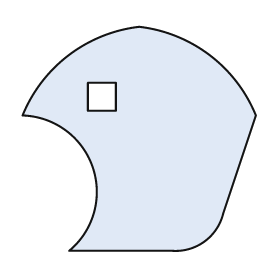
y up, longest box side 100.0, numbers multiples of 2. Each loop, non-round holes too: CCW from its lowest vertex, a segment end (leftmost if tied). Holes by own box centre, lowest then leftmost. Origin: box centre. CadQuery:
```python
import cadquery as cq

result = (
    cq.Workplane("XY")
    .moveTo(-30.0, -48.0)
    .lineTo(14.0, -48.0)
    .threePointArc((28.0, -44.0), (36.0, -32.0))
    .lineTo(50.0, 10.0)
    .threePointArc((30.0, 36.0), (0.0, 48.0))
    .threePointArc((-30.0, 36.0), (-50.0, 10.0))
    .threePointArc((-20.0, -12.0), (-30.0, -48.0))
    .close()
    .moveTo(-22.0, 12.0)
    .lineTo(-10.0, 12.0)
    .lineTo(-10.0, 24.0)
    .lineTo(-22.0, 24.0)
    .close()
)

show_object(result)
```